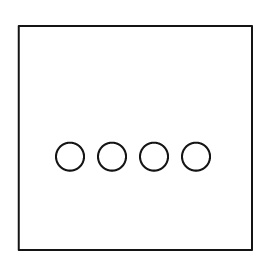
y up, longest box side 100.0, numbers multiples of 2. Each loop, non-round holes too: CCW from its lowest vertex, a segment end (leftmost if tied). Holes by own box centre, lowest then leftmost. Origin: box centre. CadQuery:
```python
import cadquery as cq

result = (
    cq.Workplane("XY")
    .moveTo(-50.0, -48.0)
    .lineTo(50.0, -48.0)
    .lineTo(50.0, 48.0)
    .lineTo(-50.0, 48.0)
    .close()
    .moveTo(-28.0, -8.0)
    .circle(6.0)
    .moveTo(-10.0, -8.0)
    .circle(6.0)
    .moveTo(8.0, -8.0)
    .circle(6.0)
    .moveTo(26.0, -8.0)
    .circle(6.0)
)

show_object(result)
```